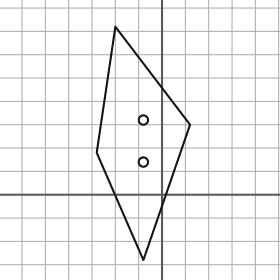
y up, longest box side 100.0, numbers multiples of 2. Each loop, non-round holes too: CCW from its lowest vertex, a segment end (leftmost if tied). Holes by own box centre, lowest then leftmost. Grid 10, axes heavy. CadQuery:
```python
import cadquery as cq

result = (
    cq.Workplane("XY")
    .moveTo(-8.0, -28.0)
    .lineTo(12.0, 30.0)
    .lineTo(-20.0, 72.0)
    .lineTo(-28.0, 18.0)
    .close()
    .moveTo(-8.0, 14.0)
    .circle(2.0)
    .moveTo(-8.0, 32.0)
    .circle(2.0)
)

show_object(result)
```